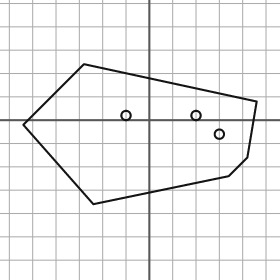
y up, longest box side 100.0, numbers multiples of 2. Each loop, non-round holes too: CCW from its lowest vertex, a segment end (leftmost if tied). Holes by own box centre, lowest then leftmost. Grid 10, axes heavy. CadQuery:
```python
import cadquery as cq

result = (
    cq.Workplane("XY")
    .moveTo(-24.0, -36.0)
    .lineTo(34.0, -24.0)
    .lineTo(42.0, -16.0)
    .lineTo(46.0, 8.0)
    .lineTo(-28.0, 24.0)
    .lineTo(-54.0, -2.0)
    .close()
    .moveTo(30.0, -6.0)
    .circle(2.0)
    .moveTo(-10.0, 2.0)
    .circle(2.0)
    .moveTo(20.0, 2.0)
    .circle(2.0)
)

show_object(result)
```